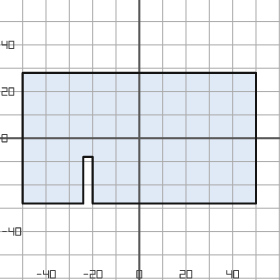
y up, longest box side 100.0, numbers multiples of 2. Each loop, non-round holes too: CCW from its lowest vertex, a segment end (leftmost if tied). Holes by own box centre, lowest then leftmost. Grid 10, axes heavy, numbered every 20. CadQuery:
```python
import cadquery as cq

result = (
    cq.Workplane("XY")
    .moveTo(-50.0, -28.0)
    .lineTo(-24.0, -28.0)
    .lineTo(-24.0, -8.0)
    .lineTo(-20.0, -8.0)
    .lineTo(-20.0, -28.0)
    .lineTo(50.0, -28.0)
    .lineTo(50.0, 28.0)
    .lineTo(-50.0, 28.0)
    .close()
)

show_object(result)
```